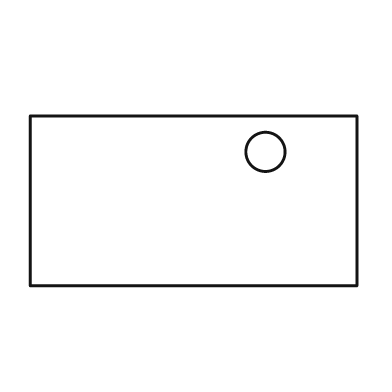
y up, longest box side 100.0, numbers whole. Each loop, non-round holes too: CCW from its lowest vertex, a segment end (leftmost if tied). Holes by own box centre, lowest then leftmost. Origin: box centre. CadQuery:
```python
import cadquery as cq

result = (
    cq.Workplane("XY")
    .moveTo(-50.0, -26.0)
    .lineTo(50.0, -26.0)
    .lineTo(50.0, 26.0)
    .lineTo(-50.0, 26.0)
    .close()
    .moveTo(22.0, 15.0)
    .circle(6.0)
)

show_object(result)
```